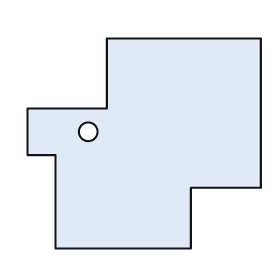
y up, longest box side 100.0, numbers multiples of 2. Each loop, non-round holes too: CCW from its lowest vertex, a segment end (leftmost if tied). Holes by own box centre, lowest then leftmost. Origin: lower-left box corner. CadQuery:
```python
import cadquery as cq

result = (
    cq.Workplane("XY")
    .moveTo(12.0, 0.0)
    .lineTo(70.0, 0.0)
    .lineTo(70.0, 26.0)
    .lineTo(100.0, 26.0)
    .lineTo(100.0, 90.0)
    .lineTo(34.0, 90.0)
    .lineTo(34.0, 60.0)
    .lineTo(0.0, 60.0)
    .lineTo(0.0, 40.0)
    .lineTo(12.0, 40.0)
    .close()
    .moveTo(26.0, 50.0)
    .circle(4.0)
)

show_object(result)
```